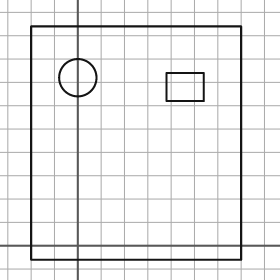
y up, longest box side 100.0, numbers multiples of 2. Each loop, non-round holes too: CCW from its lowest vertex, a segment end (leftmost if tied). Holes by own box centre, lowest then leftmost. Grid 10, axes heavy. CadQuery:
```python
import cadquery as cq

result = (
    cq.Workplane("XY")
    .moveTo(-20.0, -6.0)
    .lineTo(70.0, -6.0)
    .lineTo(70.0, 94.0)
    .lineTo(-20.0, 94.0)
    .close()
    .moveTo(38.0, 62.0)
    .lineTo(54.0, 62.0)
    .lineTo(54.0, 74.0)
    .lineTo(38.0, 74.0)
    .close()
    .moveTo(0.0, 72.0)
    .circle(8.0)
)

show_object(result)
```